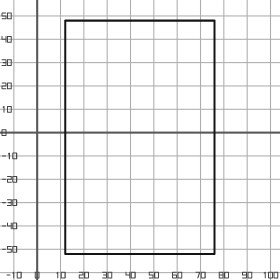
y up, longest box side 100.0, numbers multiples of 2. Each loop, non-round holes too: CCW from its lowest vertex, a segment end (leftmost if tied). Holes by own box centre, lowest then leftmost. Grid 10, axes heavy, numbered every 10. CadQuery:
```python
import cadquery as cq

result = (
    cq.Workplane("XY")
    .moveTo(12.0, -52.0)
    .lineTo(76.0, -52.0)
    .lineTo(76.0, 48.0)
    .lineTo(12.0, 48.0)
    .close()
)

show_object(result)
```